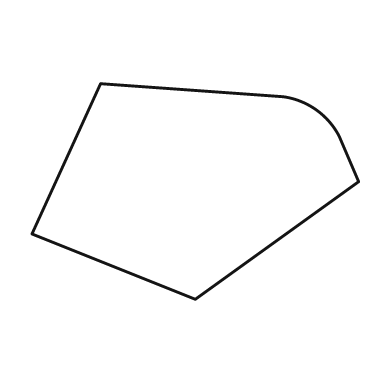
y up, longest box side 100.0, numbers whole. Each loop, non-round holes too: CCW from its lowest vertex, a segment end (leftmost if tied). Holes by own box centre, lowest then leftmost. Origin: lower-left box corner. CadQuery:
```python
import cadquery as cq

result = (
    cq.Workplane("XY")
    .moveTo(50.0, 0.0)
    .lineTo(100.0, 36.0)
    .lineTo(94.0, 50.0)
    .threePointArc((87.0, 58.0), (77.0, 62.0))
    .lineTo(21.0, 66.0)
    .lineTo(0.0, 20.0)
    .close()
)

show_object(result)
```